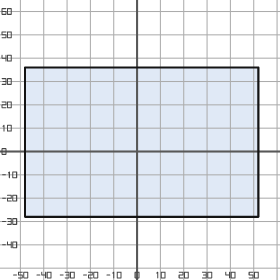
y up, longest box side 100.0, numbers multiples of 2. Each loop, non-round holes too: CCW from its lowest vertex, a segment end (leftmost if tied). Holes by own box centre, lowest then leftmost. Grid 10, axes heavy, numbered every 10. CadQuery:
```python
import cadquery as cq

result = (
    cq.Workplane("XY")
    .moveTo(-48.0, -28.0)
    .lineTo(52.0, -28.0)
    .lineTo(52.0, 36.0)
    .lineTo(-48.0, 36.0)
    .close()
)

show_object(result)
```